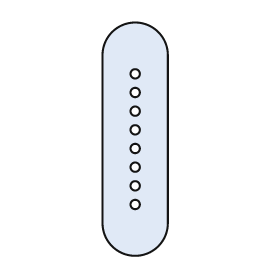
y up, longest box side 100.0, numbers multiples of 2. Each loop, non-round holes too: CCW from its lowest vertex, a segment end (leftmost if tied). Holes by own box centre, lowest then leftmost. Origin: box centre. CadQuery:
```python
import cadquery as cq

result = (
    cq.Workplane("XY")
    .moveTo(-14.0, -36.0)
    .threePointArc((0.0, -50.0), (14.0, -36.0))
    .lineTo(14.0, 36.0)
    .threePointArc((0.0, 50.0), (-14.0, 36.0))
    .close()
    .moveTo(0.0, -28.0)
    .circle(2.0)
    .moveTo(0.0, -20.0)
    .circle(2.0)
    .moveTo(0.0, -12.0)
    .circle(2.0)
    .moveTo(0.0, -4.0)
    .circle(2.0)
    .moveTo(0.0, 4.0)
    .circle(2.0)
    .moveTo(0.0, 12.0)
    .circle(2.0)
    .moveTo(0.0, 20.0)
    .circle(2.0)
    .moveTo(0.0, 28.0)
    .circle(2.0)
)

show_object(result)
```